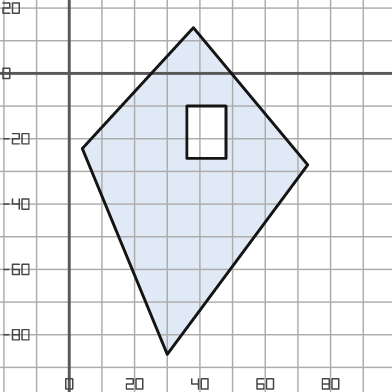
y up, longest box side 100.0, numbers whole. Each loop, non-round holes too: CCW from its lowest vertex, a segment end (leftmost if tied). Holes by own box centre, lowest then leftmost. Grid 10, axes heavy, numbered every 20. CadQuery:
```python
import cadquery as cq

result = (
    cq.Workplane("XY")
    .moveTo(30.0, -86.0)
    .lineTo(73.0, -28.0)
    .lineTo(38.0, 14.0)
    .lineTo(4.0, -23.0)
    .close()
    .moveTo(36.0, -26.0)
    .lineTo(48.0, -26.0)
    .lineTo(48.0, -10.0)
    .lineTo(36.0, -10.0)
    .close()
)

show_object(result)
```